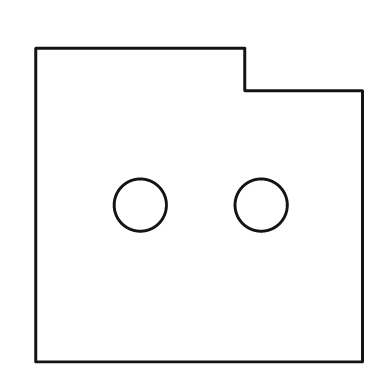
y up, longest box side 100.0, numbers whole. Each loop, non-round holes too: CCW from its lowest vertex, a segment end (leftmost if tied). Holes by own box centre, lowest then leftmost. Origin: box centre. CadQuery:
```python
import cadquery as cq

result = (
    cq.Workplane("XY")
    .moveTo(-50.0, -48.0)
    .lineTo(50.0, -48.0)
    .lineTo(50.0, 35.0)
    .lineTo(14.0, 35.0)
    .lineTo(14.0, 48.0)
    .lineTo(-50.0, 48.0)
    .close()
    .moveTo(-18.0, 0.0)
    .circle(8.0)
    .moveTo(19.0, 0.0)
    .circle(8.0)
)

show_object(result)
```